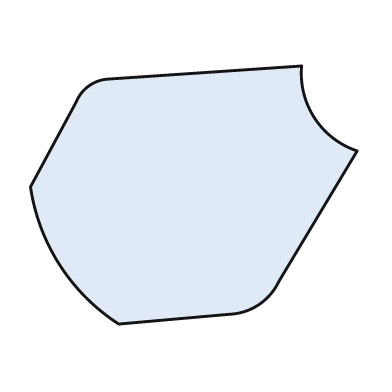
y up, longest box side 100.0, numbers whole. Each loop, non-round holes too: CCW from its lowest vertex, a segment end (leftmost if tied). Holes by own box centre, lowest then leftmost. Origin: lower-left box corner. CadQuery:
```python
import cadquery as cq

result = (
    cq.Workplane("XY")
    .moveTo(27.0, 0.0)
    .lineTo(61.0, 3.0)
    .threePointArc((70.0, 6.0), (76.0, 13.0))
    .lineTo(100.0, 53.0)
    .threePointArc((87.0, 63.0), (83.0, 79.0))
    .lineTo(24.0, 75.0)
    .threePointArc((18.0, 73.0), (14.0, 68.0))
    .lineTo(0.0, 42.0)
    .threePointArc((9.0, 18.0), (27.0, 0.0))
    .close()
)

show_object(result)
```